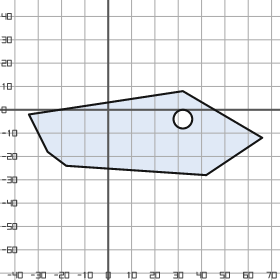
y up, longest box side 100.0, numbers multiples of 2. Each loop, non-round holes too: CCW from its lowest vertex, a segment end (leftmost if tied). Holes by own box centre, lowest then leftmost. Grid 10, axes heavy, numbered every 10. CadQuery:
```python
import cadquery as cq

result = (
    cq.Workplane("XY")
    .moveTo(42.0, -28.0)
    .lineTo(66.0, -12.0)
    .lineTo(32.0, 8.0)
    .lineTo(-34.0, -2.0)
    .lineTo(-26.0, -18.0)
    .lineTo(-18.0, -24.0)
    .close()
    .moveTo(32.0, -4.0)
    .circle(4.0)
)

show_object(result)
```